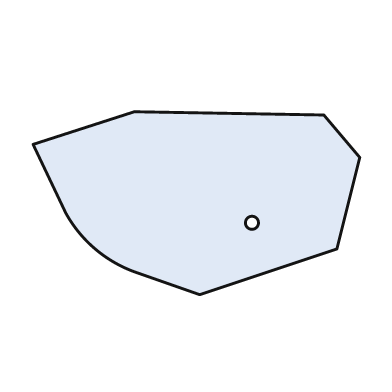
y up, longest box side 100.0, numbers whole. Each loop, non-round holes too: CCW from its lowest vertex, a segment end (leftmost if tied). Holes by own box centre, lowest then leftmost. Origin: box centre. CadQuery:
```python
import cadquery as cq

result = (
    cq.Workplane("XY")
    .moveTo(1.0, -28.0)
    .lineTo(43.0, -14.0)
    .lineTo(50.0, 14.0)
    .lineTo(39.0, 27.0)
    .lineTo(-19.0, 28.0)
    .lineTo(-50.0, 18.0)
    .lineTo(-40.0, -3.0)
    .threePointArc((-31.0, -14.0), (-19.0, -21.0))
    .close()
    .moveTo(17.0, -6.0)
    .circle(2.0)
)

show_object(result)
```